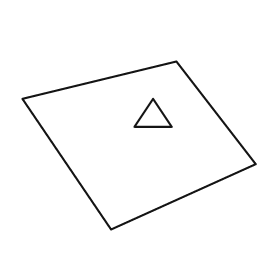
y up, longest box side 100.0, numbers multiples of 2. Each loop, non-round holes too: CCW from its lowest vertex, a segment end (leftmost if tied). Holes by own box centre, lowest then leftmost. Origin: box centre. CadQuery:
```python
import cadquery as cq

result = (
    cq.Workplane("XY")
    .moveTo(-12.0, -36.0)
    .lineTo(50.0, -8.0)
    .lineTo(16.0, 36.0)
    .lineTo(-50.0, 20.0)
    .close()
    .moveTo(-2.0, 8.0)
    .lineTo(14.0, 8.0)
    .lineTo(6.0, 20.0)
    .close()
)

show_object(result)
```